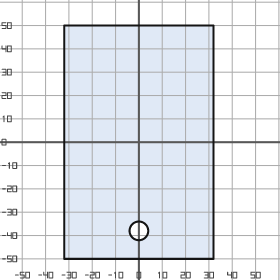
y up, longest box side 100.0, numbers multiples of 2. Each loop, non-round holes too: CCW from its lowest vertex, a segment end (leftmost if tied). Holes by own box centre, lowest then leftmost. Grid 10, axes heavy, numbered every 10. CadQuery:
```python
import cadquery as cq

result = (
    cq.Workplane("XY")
    .moveTo(-32.0, -50.0)
    .lineTo(32.0, -50.0)
    .lineTo(32.0, 50.0)
    .lineTo(-32.0, 50.0)
    .close()
    .moveTo(0.0, -38.0)
    .circle(4.0)
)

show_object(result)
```